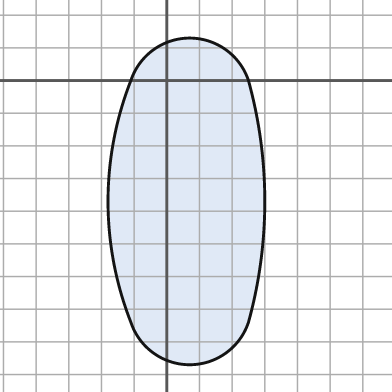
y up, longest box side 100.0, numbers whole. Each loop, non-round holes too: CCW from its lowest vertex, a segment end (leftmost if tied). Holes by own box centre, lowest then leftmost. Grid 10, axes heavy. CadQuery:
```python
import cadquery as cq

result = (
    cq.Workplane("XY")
    .moveTo(-11.0, -74.0)
    .threePointArc((7.0, -87.0), (25.0, -74.0))
    .threePointArc((30.0, -37.0), (25.0, 0.0))
    .threePointArc((7.0, 13.0), (-11.0, 0.0))
    .threePointArc((-18.0, -37.0), (-11.0, -74.0))
    .close()
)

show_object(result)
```